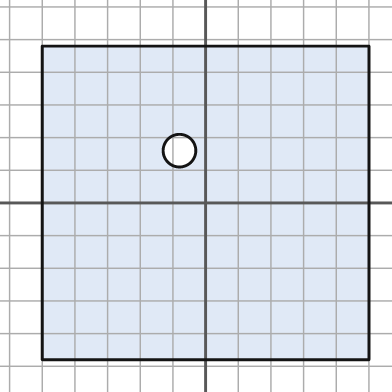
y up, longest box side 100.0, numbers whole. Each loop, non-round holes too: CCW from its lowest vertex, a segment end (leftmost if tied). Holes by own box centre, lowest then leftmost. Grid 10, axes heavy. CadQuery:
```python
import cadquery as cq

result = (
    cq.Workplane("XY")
    .moveTo(-50.0, -48.0)
    .lineTo(50.0, -48.0)
    .lineTo(50.0, 48.0)
    .lineTo(-50.0, 48.0)
    .close()
    .moveTo(-8.0, 16.0)
    .circle(5.0)
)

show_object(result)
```